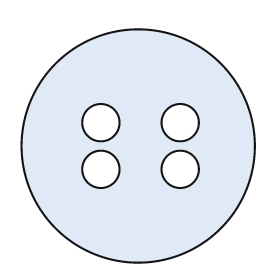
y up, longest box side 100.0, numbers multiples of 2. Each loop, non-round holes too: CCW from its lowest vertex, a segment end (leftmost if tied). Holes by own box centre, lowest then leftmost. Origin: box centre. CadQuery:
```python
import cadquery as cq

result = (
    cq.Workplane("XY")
    .moveTo(0.0, 0.0)
    .circle(50.0)
    .moveTo(-16.0, -10.0)
    .circle(8.0)
    .moveTo(18.0, -10.0)
    .circle(8.0)
    .moveTo(-16.0, 10.0)
    .circle(8.0)
    .moveTo(18.0, 10.0)
    .circle(8.0)
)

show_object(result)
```